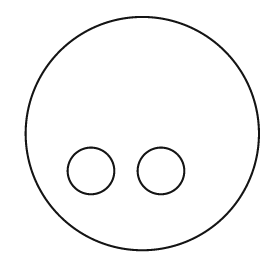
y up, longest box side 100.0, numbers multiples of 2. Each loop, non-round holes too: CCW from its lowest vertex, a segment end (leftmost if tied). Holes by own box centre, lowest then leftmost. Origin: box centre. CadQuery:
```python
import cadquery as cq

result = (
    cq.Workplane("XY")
    .moveTo(0.0, 0.0)
    .circle(50.0)
    .moveTo(-22.0, -16.0)
    .circle(10.0)
    .moveTo(8.0, -16.0)
    .circle(10.0)
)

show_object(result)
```